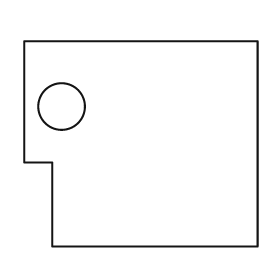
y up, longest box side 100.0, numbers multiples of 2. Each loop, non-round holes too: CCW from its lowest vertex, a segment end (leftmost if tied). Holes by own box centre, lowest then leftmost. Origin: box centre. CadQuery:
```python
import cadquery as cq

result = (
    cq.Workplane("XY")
    .moveTo(-38.0, -44.0)
    .lineTo(50.0, -44.0)
    .lineTo(50.0, 44.0)
    .lineTo(-50.0, 44.0)
    .lineTo(-50.0, -8.0)
    .lineTo(-38.0, -8.0)
    .close()
    .moveTo(-34.0, 16.0)
    .circle(10.0)
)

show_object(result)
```